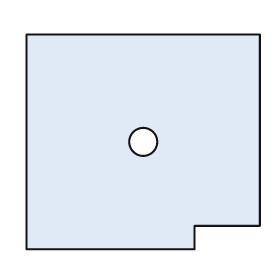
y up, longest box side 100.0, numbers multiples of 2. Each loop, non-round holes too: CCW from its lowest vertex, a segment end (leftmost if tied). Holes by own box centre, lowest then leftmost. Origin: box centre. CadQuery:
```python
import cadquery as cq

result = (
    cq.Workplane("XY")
    .moveTo(-50.0, -46.0)
    .lineTo(22.0, -46.0)
    .lineTo(22.0, -36.0)
    .lineTo(50.0, -36.0)
    .lineTo(50.0, 46.0)
    .lineTo(-50.0, 46.0)
    .close()
    .moveTo(0.0, 0.0)
    .circle(6.0)
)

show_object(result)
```